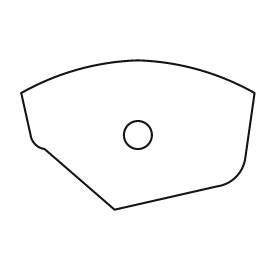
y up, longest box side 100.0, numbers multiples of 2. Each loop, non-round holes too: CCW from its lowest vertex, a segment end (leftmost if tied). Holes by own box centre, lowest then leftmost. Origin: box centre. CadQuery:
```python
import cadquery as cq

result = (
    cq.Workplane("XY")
    .moveTo(-10.0, -32.0)
    .lineTo(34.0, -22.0)
    .threePointArc((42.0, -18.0), (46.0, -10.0))
    .lineTo(50.0, 18.0)
    .threePointArc((26.0, 28.0), (0.0, 32.0))
    .threePointArc((-26.0, 28.0), (-50.0, 18.0))
    .lineTo(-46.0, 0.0)
    .threePointArc((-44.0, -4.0), (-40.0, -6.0))
    .close()
    .moveTo(0.0, 0.0)
    .circle(6.0)
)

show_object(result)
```